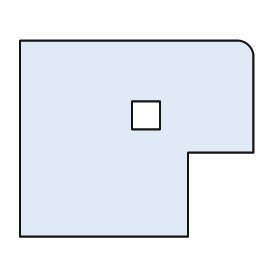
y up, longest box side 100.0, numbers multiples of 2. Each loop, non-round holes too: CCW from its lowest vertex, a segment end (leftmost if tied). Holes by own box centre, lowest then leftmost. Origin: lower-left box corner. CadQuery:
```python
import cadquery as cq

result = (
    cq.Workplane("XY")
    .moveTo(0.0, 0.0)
    .lineTo(72.0, 0.0)
    .lineTo(72.0, 36.0)
    .lineTo(100.0, 36.0)
    .lineTo(100.0, 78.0)
    .threePointArc((98.0, 82.0), (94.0, 84.0))
    .lineTo(0.0, 84.0)
    .close()
    .moveTo(48.0, 46.0)
    .lineTo(60.0, 46.0)
    .lineTo(60.0, 58.0)
    .lineTo(48.0, 58.0)
    .close()
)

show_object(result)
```